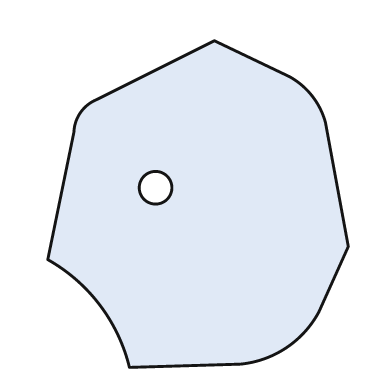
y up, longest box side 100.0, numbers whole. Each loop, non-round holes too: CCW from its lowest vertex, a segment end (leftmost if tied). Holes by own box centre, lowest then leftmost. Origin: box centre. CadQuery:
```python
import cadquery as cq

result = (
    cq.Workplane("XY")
    .moveTo(-21.0, -50.0)
    .lineTo(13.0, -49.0)
    .threePointArc((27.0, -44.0), (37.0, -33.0))
    .lineTo(46.0, -13.0)
    .lineTo(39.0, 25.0)
    .threePointArc((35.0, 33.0), (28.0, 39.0))
    .lineTo(5.0, 50.0)
    .lineTo(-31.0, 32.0)
    .threePointArc((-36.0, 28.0), (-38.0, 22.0))
    .lineTo(-46.0, -17.0)
    .threePointArc((-30.0, -31.0), (-21.0, -50.0))
    .close()
    .moveTo(-13.0, 5.0)
    .circle(5.0)
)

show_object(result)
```